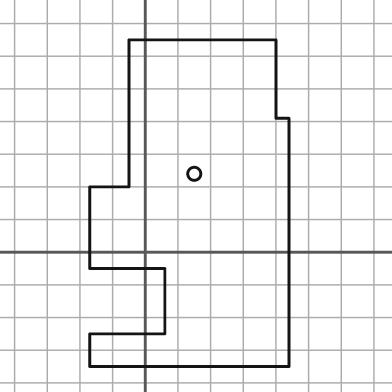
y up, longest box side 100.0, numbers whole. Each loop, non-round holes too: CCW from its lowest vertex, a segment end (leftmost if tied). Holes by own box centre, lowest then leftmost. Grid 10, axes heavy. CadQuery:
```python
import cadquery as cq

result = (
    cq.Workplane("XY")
    .moveTo(-17.0, -35.0)
    .lineTo(44.0, -35.0)
    .lineTo(44.0, 41.0)
    .lineTo(40.0, 41.0)
    .lineTo(40.0, 65.0)
    .lineTo(-5.0, 65.0)
    .lineTo(-5.0, 20.0)
    .lineTo(-17.0, 20.0)
    .lineTo(-17.0, -5.0)
    .lineTo(6.0, -5.0)
    .lineTo(6.0, -25.0)
    .lineTo(-17.0, -25.0)
    .close()
    .moveTo(15.0, 24.0)
    .circle(2.0)
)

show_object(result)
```